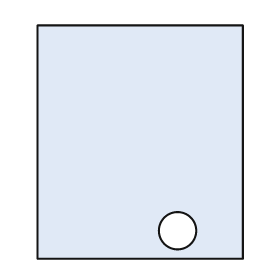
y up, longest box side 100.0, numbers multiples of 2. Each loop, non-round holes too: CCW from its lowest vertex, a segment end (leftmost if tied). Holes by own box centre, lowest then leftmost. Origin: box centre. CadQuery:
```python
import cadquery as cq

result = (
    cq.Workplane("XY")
    .moveTo(-44.0, -50.0)
    .lineTo(44.0, -50.0)
    .lineTo(44.0, 50.0)
    .lineTo(-44.0, 50.0)
    .close()
    .moveTo(16.0, -38.0)
    .circle(8.0)
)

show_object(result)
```